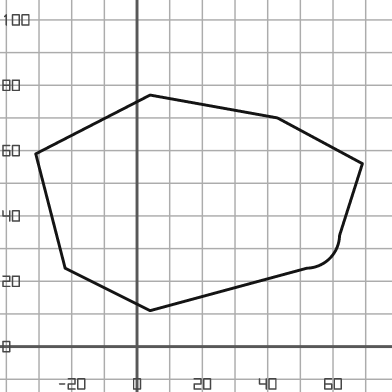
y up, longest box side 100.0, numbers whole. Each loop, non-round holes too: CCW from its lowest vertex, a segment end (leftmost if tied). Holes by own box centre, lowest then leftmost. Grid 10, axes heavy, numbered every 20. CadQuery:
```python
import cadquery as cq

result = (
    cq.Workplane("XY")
    .moveTo(4.0, 11.0)
    .lineTo(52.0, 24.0)
    .threePointArc((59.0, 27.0), (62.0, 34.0))
    .lineTo(69.0, 56.0)
    .lineTo(43.0, 70.0)
    .lineTo(4.0, 77.0)
    .lineTo(-31.0, 59.0)
    .lineTo(-22.0, 24.0)
    .close()
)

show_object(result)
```